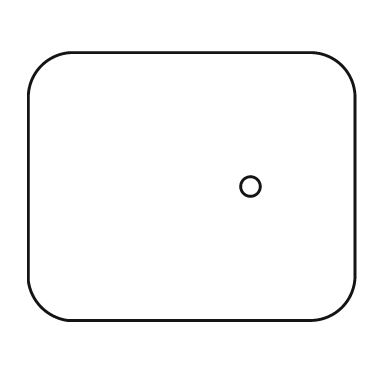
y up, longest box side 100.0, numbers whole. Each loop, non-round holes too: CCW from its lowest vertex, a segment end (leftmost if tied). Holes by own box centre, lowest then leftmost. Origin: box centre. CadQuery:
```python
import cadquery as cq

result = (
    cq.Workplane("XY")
    .moveTo(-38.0, -41.0)
    .lineTo(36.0, -41.0)
    .threePointArc((46.0, -37.0), (50.0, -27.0))
    .lineTo(50.0, 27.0)
    .threePointArc((46.0, 37.0), (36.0, 41.0))
    .lineTo(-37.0, 41.0)
    .threePointArc((-46.0, 37.0), (-50.0, 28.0))
    .lineTo(-50.0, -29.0)
    .threePointArc((-46.0, -37.0), (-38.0, -41.0))
    .close()
    .moveTo(18.0, 0.0)
    .circle(3.0)
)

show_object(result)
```